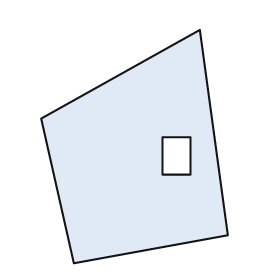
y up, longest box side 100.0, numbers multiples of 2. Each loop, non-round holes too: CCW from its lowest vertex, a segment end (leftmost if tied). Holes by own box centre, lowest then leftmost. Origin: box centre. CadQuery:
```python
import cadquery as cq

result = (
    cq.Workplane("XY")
    .moveTo(-26.0, -50.0)
    .lineTo(40.0, -38.0)
    .lineTo(28.0, 50.0)
    .lineTo(-40.0, 12.0)
    .close()
    .moveTo(12.0, -12.0)
    .lineTo(24.0, -12.0)
    .lineTo(24.0, 4.0)
    .lineTo(12.0, 4.0)
    .close()
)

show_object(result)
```